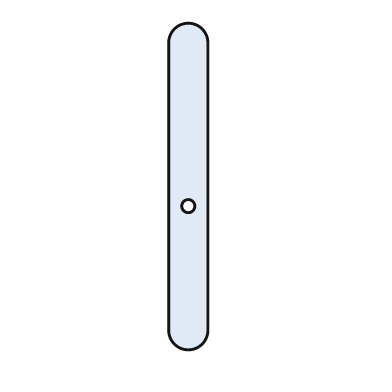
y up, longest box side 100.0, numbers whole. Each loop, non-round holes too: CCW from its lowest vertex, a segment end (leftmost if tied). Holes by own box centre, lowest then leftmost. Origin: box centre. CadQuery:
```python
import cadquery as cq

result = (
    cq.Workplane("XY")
    .moveTo(-6.0, -44.0)
    .threePointArc((0.0, -50.0), (6.0, -44.0))
    .lineTo(6.0, 44.0)
    .threePointArc((0.0, 50.0), (-6.0, 44.0))
    .close()
    .moveTo(0.0, -6.0)
    .circle(2.0)
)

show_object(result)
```